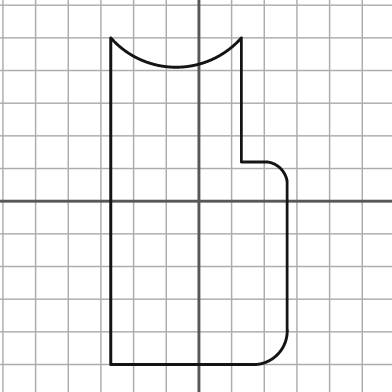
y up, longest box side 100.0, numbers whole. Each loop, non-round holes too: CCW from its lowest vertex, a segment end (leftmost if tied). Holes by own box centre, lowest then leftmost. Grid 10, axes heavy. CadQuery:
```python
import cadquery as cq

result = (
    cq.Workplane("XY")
    .moveTo(-27.0, -50.0)
    .lineTo(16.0, -50.0)
    .threePointArc((24.0, -47.0), (27.0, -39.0))
    .lineTo(27.0, 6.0)
    .threePointArc((25.0, 10.0), (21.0, 12.0))
    .lineTo(13.0, 12.0)
    .lineTo(13.0, 50.0)
    .threePointArc((-7.0, 41.0), (-27.0, 50.0))
    .close()
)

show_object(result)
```